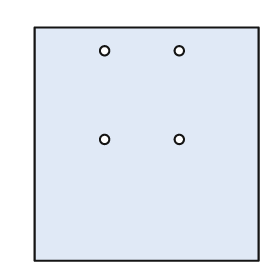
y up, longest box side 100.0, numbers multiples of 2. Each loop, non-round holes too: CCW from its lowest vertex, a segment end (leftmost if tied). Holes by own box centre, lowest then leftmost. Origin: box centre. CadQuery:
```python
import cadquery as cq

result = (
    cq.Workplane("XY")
    .moveTo(-48.0, -50.0)
    .lineTo(48.0, -50.0)
    .lineTo(48.0, 50.0)
    .lineTo(-48.0, 50.0)
    .close()
    .moveTo(-18.0, 2.0)
    .circle(2.0)
    .moveTo(14.0, 2.0)
    .circle(2.0)
    .moveTo(-18.0, 40.0)
    .circle(2.0)
    .moveTo(14.0, 40.0)
    .circle(2.0)
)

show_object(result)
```